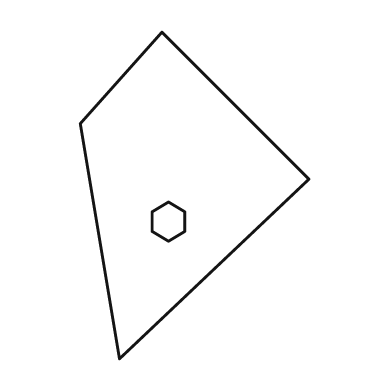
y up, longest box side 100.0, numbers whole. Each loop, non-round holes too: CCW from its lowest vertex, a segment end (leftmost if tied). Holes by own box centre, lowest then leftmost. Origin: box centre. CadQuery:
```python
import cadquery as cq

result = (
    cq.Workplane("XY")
    .moveTo(-23.0, -50.0)
    .lineTo(35.0, 5.0)
    .lineTo(-10.0, 50.0)
    .lineTo(-35.0, 22.0)
    .close()
    .moveTo(-8.0, -14.0)
    .lineTo(-3.0, -11.0)
    .lineTo(-3.0, -5.0)
    .lineTo(-8.0, -2.0)
    .lineTo(-13.0, -5.0)
    .lineTo(-13.0, -11.0)
    .close()
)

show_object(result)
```